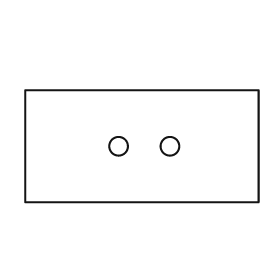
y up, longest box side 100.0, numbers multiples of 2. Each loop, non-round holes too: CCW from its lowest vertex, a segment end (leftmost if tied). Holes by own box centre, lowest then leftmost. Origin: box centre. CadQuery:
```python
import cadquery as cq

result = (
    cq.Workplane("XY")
    .moveTo(-50.0, -24.0)
    .lineTo(50.0, -24.0)
    .lineTo(50.0, 24.0)
    .lineTo(-50.0, 24.0)
    .close()
    .moveTo(-10.0, 0.0)
    .circle(4.0)
    .moveTo(12.0, 0.0)
    .circle(4.0)
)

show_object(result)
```